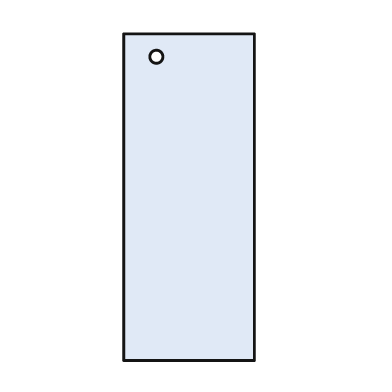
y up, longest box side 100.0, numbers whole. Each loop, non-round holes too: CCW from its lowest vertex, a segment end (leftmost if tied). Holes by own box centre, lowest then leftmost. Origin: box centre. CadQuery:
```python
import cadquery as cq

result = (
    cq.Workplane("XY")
    .moveTo(-20.0, -50.0)
    .lineTo(20.0, -50.0)
    .lineTo(20.0, 50.0)
    .lineTo(-20.0, 50.0)
    .close()
    .moveTo(-10.0, 43.0)
    .circle(2.0)
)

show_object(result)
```